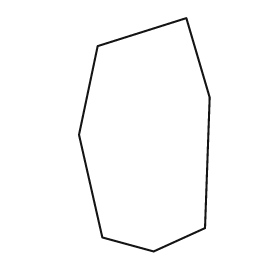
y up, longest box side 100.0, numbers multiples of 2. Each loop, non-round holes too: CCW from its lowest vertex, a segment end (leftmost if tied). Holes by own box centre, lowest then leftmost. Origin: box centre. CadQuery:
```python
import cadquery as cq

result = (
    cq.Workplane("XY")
    .moveTo(4.0, -50.0)
    .lineTo(26.0, -40.0)
    .lineTo(28.0, 16.0)
    .lineTo(18.0, 50.0)
    .lineTo(-20.0, 38.0)
    .lineTo(-28.0, 0.0)
    .lineTo(-18.0, -44.0)
    .close()
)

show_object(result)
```